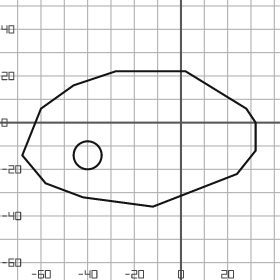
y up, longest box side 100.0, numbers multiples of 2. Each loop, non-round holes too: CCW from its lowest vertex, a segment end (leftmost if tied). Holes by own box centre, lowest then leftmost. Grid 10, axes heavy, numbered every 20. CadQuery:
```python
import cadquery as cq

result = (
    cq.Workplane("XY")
    .moveTo(-12.0, -36.0)
    .lineTo(24.0, -22.0)
    .lineTo(32.0, -12.0)
    .lineTo(32.0, 0.0)
    .lineTo(28.0, 6.0)
    .lineTo(2.0, 22.0)
    .lineTo(-28.0, 22.0)
    .lineTo(-46.0, 16.0)
    .lineTo(-60.0, 6.0)
    .lineTo(-68.0, -14.0)
    .lineTo(-58.0, -26.0)
    .lineTo(-42.0, -32.0)
    .close()
    .moveTo(-40.0, -14.0)
    .circle(6.0)
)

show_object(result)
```